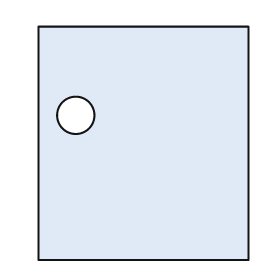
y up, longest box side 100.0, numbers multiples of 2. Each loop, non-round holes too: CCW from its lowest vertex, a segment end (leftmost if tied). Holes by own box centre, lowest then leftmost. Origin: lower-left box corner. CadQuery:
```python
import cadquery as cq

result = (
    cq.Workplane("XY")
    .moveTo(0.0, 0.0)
    .lineTo(90.0, 0.0)
    .lineTo(90.0, 100.0)
    .lineTo(0.0, 100.0)
    .close()
    .moveTo(16.0, 62.0)
    .circle(8.0)
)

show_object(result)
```